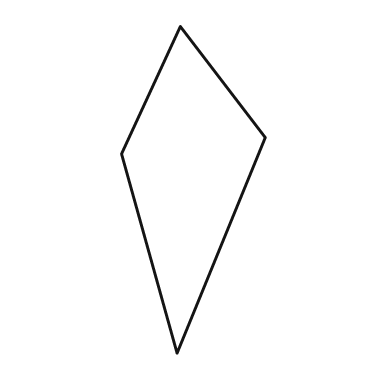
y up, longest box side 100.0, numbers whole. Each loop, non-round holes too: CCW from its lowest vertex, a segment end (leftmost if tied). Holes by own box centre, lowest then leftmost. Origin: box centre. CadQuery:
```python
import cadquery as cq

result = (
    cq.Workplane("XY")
    .moveTo(-5.0, -50.0)
    .lineTo(22.0, 16.0)
    .lineTo(-4.0, 50.0)
    .lineTo(-22.0, 11.0)
    .close()
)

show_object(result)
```